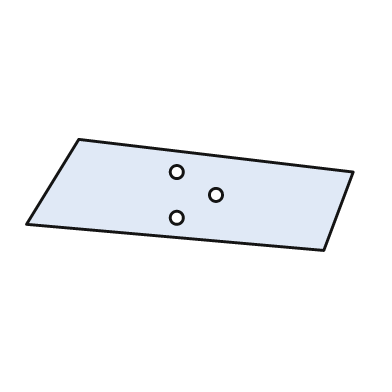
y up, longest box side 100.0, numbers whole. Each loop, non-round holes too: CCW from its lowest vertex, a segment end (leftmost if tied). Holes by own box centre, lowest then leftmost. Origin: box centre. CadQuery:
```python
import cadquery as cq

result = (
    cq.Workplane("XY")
    .moveTo(41.0, -17.0)
    .lineTo(50.0, 7.0)
    .lineTo(-34.0, 17.0)
    .lineTo(-50.0, -9.0)
    .close()
    .moveTo(-4.0, -7.0)
    .circle(2.0)
    .moveTo(8.0, 0.0)
    .circle(2.0)
    .moveTo(-4.0, 7.0)
    .circle(2.0)
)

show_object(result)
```